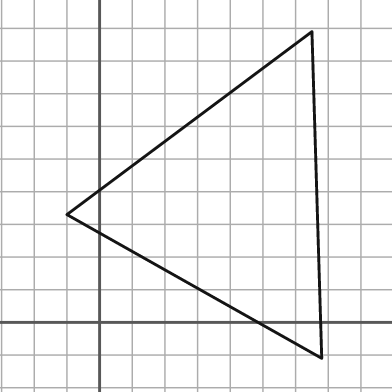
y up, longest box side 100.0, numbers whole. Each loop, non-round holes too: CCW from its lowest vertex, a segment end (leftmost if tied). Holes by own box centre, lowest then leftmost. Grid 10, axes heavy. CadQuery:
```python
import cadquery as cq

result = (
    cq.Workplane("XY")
    .moveTo(68.0, -11.0)
    .lineTo(65.0, 89.0)
    .lineTo(-10.0, 33.0)
    .close()
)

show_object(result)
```